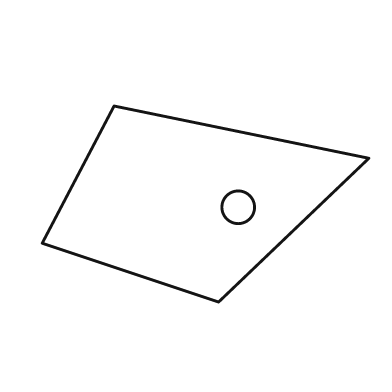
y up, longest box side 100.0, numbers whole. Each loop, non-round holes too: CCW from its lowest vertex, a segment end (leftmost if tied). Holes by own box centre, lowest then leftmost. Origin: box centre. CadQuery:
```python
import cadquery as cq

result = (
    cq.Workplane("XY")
    .moveTo(4.0, -30.0)
    .lineTo(50.0, 14.0)
    .lineTo(-28.0, 30.0)
    .lineTo(-50.0, -12.0)
    .close()
    .moveTo(10.0, -1.0)
    .circle(5.0)
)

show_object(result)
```